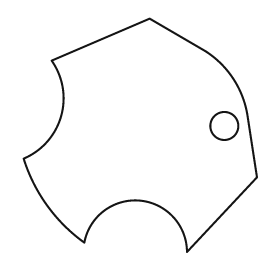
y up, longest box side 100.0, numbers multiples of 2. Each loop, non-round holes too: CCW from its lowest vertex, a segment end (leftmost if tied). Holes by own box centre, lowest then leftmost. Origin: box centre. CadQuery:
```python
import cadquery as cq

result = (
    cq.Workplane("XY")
    .moveTo(20.0, -50.0)
    .lineTo(50.0, -18.0)
    .lineTo(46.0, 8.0)
    .threePointArc((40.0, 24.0), (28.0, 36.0))
    .lineTo(4.0, 50.0)
    .lineTo(-38.0, 32.0)
    .threePointArc((-34.0, 8.0), (-50.0, -10.0))
    .threePointArc((-40.0, -30.0), (-24.0, -46.0))
    .threePointArc((0.0, -28.0), (20.0, -50.0))
    .close()
    .moveTo(36.0, 4.0)
    .circle(6.0)
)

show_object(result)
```